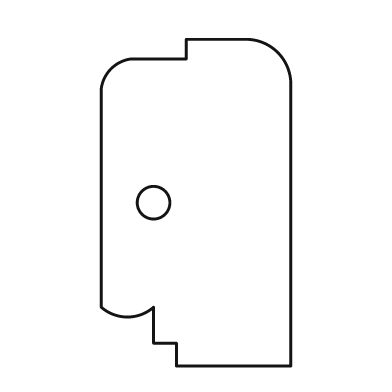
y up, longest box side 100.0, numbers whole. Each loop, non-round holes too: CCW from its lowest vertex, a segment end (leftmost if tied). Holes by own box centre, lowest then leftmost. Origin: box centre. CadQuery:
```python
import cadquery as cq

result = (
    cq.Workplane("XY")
    .moveTo(-6.0, -50.0)
    .lineTo(29.0, -50.0)
    .lineTo(29.0, 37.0)
    .threePointArc((25.0, 46.0), (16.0, 50.0))
    .lineTo(-3.0, 50.0)
    .lineTo(-3.0, 44.0)
    .lineTo(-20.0, 44.0)
    .threePointArc((-26.0, 41.0), (-29.0, 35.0))
    .lineTo(-29.0, -32.0)
    .threePointArc((-21.0, -35.0), (-13.0, -32.0))
    .lineTo(-13.0, -43.0)
    .lineTo(-6.0, -43.0)
    .close()
    .moveTo(-13.0, 0.0)
    .circle(5.0)
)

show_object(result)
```